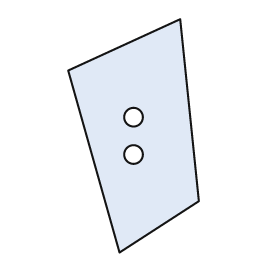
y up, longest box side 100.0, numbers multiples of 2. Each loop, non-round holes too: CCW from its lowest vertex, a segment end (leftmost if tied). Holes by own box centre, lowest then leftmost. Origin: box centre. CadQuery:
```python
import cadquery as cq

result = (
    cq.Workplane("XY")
    .moveTo(-6.0, -50.0)
    .lineTo(28.0, -28.0)
    .lineTo(20.0, 50.0)
    .lineTo(-28.0, 28.0)
    .close()
    .moveTo(0.0, -8.0)
    .circle(4.0)
    .moveTo(0.0, 8.0)
    .circle(4.0)
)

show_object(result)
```